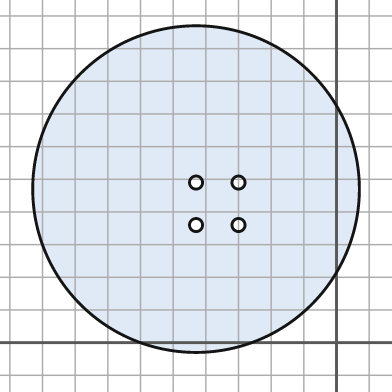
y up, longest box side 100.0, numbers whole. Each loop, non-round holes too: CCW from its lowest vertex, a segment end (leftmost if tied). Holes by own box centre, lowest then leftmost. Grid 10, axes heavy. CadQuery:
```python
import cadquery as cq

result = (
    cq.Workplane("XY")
    .moveTo(-43.0, 47.0)
    .circle(50.0)
    .moveTo(-43.0, 36.0)
    .circle(2.0)
    .moveTo(-30.0, 36.0)
    .circle(2.0)
    .moveTo(-43.0, 49.0)
    .circle(2.0)
    .moveTo(-30.0, 49.0)
    .circle(2.0)
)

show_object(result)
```